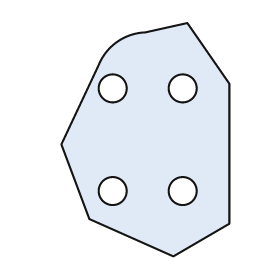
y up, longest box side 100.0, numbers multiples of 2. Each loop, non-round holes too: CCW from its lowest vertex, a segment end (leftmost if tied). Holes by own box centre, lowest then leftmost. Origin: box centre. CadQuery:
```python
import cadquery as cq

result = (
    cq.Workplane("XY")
    .moveTo(12.0, -50.0)
    .lineTo(36.0, -36.0)
    .lineTo(36.0, 24.0)
    .lineTo(18.0, 50.0)
    .lineTo(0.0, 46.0)
    .threePointArc((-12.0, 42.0), (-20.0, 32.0))
    .lineTo(-36.0, -2.0)
    .lineTo(-24.0, -34.0)
    .close()
    .moveTo(-14.0, -22.0)
    .circle(6.0)
    .moveTo(16.0, -22.0)
    .circle(6.0)
    .moveTo(-14.0, 22.0)
    .circle(6.0)
    .moveTo(16.0, 22.0)
    .circle(6.0)
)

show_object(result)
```